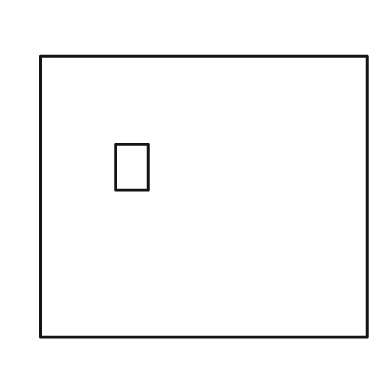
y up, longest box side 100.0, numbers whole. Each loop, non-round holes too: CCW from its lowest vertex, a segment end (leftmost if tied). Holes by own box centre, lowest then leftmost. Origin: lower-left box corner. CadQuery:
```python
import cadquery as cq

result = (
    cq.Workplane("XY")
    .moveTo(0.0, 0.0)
    .lineTo(100.0, 0.0)
    .lineTo(100.0, 86.0)
    .lineTo(0.0, 86.0)
    .close()
    .moveTo(23.0, 45.0)
    .lineTo(33.0, 45.0)
    .lineTo(33.0, 59.0)
    .lineTo(23.0, 59.0)
    .close()
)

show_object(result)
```